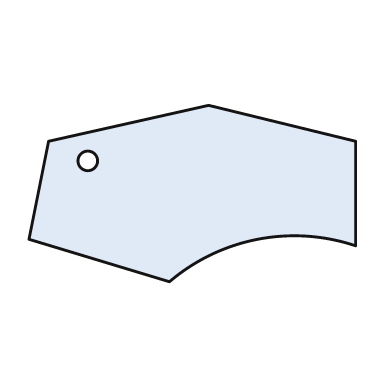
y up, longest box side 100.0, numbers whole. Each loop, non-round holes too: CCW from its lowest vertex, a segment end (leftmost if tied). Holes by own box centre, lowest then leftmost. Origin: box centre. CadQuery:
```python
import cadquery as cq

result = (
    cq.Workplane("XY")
    .moveTo(-7.0, -27.0)
    .threePointArc((20.0, -14.0), (50.0, -16.0))
    .lineTo(50.0, 16.0)
    .lineTo(5.0, 27.0)
    .lineTo(-44.0, 16.0)
    .lineTo(-50.0, -14.0)
    .close()
    .moveTo(-32.0, 10.0)
    .circle(3.0)
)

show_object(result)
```